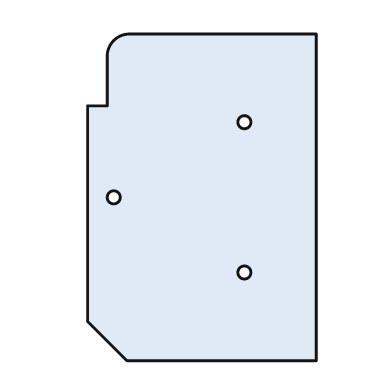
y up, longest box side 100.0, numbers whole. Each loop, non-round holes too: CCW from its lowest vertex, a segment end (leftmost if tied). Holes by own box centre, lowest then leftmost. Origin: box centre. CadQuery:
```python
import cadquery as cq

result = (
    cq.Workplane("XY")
    .moveTo(-23.0, -50.0)
    .lineTo(35.0, -50.0)
    .lineTo(35.0, 50.0)
    .lineTo(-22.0, 50.0)
    .threePointArc((-27.0, 48.0), (-29.0, 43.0))
    .lineTo(-29.0, 28.0)
    .lineTo(-35.0, 28.0)
    .lineTo(-35.0, -38.0)
    .close()
    .moveTo(13.0, -23.0)
    .circle(2.0)
    .moveTo(-27.0, 0.0)
    .circle(2.0)
    .moveTo(13.0, 23.0)
    .circle(2.0)
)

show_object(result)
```